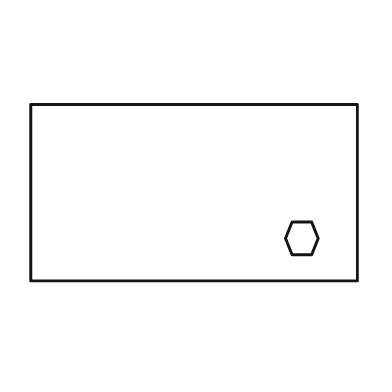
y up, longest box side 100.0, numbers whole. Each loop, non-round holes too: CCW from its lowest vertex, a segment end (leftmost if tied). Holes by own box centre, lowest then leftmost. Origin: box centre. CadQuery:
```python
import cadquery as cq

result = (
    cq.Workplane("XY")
    .moveTo(-50.0, -27.0)
    .lineTo(50.0, -27.0)
    .lineTo(50.0, 27.0)
    .lineTo(-50.0, 27.0)
    .close()
    .moveTo(30.0, -19.0)
    .lineTo(36.0, -19.0)
    .lineTo(38.0, -14.0)
    .lineTo(36.0, -9.0)
    .lineTo(30.0, -9.0)
    .lineTo(28.0, -14.0)
    .close()
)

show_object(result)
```